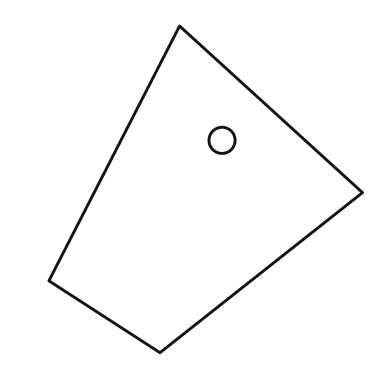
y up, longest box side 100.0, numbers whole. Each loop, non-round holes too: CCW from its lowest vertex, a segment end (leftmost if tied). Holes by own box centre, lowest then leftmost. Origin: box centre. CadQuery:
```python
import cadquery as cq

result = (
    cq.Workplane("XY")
    .moveTo(-14.0, -50.0)
    .lineTo(48.0, -1.0)
    .lineTo(-8.0, 50.0)
    .lineTo(-48.0, -28.0)
    .close()
    .moveTo(5.0, 15.0)
    .circle(4.0)
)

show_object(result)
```